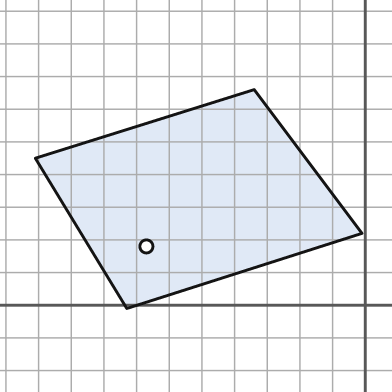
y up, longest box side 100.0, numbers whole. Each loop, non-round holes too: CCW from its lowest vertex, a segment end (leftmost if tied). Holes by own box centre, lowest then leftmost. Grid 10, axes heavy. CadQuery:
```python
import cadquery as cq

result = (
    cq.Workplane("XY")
    .moveTo(-73.0, -1.0)
    .lineTo(-1.0, 22.0)
    .lineTo(-34.0, 66.0)
    .lineTo(-101.0, 45.0)
    .close()
    .moveTo(-67.0, 18.0)
    .circle(2.0)
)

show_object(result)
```